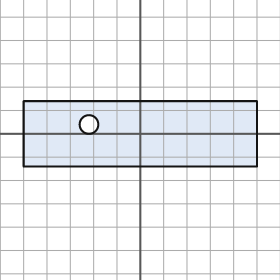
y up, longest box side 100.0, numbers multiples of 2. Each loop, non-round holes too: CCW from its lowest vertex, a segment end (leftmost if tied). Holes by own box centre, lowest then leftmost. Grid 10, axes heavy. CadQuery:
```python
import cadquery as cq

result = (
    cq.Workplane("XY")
    .moveTo(-50.0, -14.0)
    .lineTo(50.0, -14.0)
    .lineTo(50.0, 14.0)
    .lineTo(-50.0, 14.0)
    .close()
    .moveTo(-22.0, 4.0)
    .circle(4.0)
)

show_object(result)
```